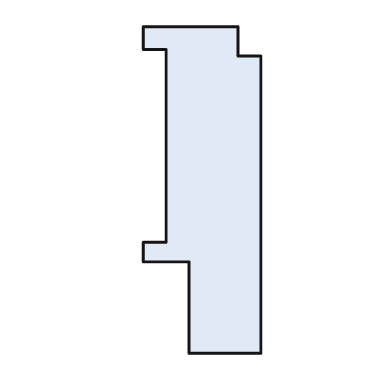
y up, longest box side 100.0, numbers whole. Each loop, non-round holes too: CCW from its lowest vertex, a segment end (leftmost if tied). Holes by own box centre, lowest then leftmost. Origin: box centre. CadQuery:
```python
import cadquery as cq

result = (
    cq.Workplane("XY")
    .moveTo(-4.0, -50.0)
    .lineTo(18.0, -50.0)
    .lineTo(18.0, 41.0)
    .lineTo(11.0, 41.0)
    .lineTo(11.0, 50.0)
    .lineTo(-18.0, 50.0)
    .lineTo(-18.0, 43.0)
    .lineTo(-11.0, 43.0)
    .lineTo(-11.0, -16.0)
    .lineTo(-18.0, -16.0)
    .lineTo(-18.0, -22.0)
    .lineTo(-4.0, -22.0)
    .close()
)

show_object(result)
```